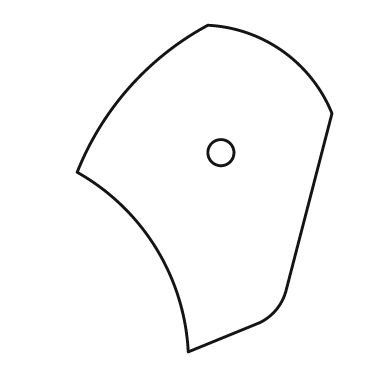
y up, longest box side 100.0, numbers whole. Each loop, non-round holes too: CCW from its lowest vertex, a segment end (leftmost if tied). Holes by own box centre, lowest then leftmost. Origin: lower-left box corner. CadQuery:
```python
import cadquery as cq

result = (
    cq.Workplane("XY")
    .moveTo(34.0, 0.0)
    .lineTo(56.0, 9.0)
    .threePointArc((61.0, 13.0), (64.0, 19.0))
    .lineTo(78.0, 73.0)
    .threePointArc((63.0, 92.0), (40.0, 100.0))
    .threePointArc((16.0, 81.0), (0.0, 55.0))
    .threePointArc((24.0, 32.0), (34.0, 0.0))
    .close()
    .moveTo(44.0, 61.0)
    .circle(4.0)
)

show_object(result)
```